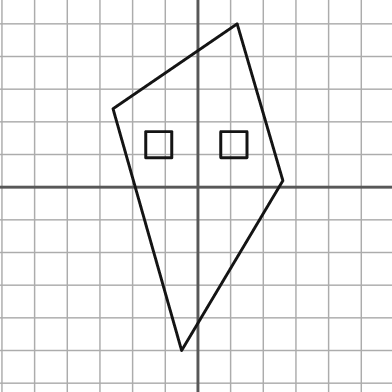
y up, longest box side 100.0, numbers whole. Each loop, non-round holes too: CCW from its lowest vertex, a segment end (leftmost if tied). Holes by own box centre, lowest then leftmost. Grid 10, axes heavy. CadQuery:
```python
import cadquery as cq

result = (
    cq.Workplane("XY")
    .moveTo(-5.0, -50.0)
    .lineTo(26.0, 2.0)
    .lineTo(12.0, 50.0)
    .lineTo(-26.0, 24.0)
    .close()
    .moveTo(-16.0, 9.0)
    .lineTo(-8.0, 9.0)
    .lineTo(-8.0, 17.0)
    .lineTo(-16.0, 17.0)
    .close()
    .moveTo(7.0, 9.0)
    .lineTo(15.0, 9.0)
    .lineTo(15.0, 17.0)
    .lineTo(7.0, 17.0)
    .close()
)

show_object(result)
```